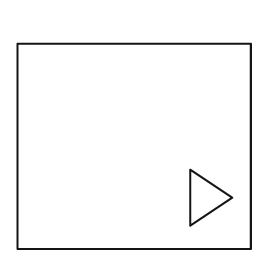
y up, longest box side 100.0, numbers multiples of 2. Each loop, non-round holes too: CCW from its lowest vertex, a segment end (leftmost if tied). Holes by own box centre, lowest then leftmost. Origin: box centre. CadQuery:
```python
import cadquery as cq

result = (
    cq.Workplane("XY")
    .moveTo(-50.0, -44.0)
    .lineTo(50.0, -44.0)
    .lineTo(50.0, 44.0)
    .lineTo(-50.0, 44.0)
    .close()
    .moveTo(24.0, -34.0)
    .lineTo(42.0, -22.0)
    .lineTo(24.0, -10.0)
    .close()
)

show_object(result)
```